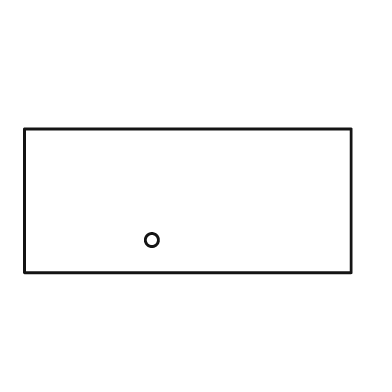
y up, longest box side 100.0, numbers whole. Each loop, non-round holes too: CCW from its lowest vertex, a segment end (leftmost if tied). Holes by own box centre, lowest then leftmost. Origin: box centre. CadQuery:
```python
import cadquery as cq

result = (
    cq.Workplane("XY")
    .moveTo(-50.0, -22.0)
    .lineTo(50.0, -22.0)
    .lineTo(50.0, 22.0)
    .lineTo(-50.0, 22.0)
    .close()
    .moveTo(-11.0, -12.0)
    .circle(2.0)
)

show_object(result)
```